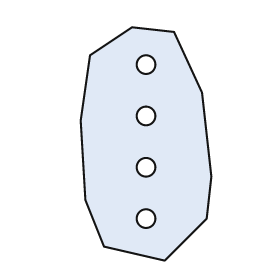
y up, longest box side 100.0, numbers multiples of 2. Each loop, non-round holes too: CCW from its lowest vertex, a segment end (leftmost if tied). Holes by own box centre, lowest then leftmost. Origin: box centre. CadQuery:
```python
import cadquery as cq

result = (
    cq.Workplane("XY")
    .moveTo(8.0, -50.0)
    .lineTo(26.0, -32.0)
    .lineTo(28.0, -14.0)
    .lineTo(24.0, 22.0)
    .lineTo(12.0, 48.0)
    .lineTo(-6.0, 50.0)
    .lineTo(-24.0, 38.0)
    .lineTo(-28.0, 10.0)
    .lineTo(-26.0, -24.0)
    .lineTo(-18.0, -44.0)
    .close()
    .moveTo(0.0, -32.0)
    .circle(4.0)
    .moveTo(0.0, -10.0)
    .circle(4.0)
    .moveTo(0.0, 12.0)
    .circle(4.0)
    .moveTo(0.0, 34.0)
    .circle(4.0)
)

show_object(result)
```